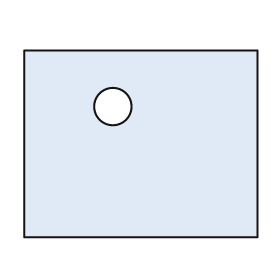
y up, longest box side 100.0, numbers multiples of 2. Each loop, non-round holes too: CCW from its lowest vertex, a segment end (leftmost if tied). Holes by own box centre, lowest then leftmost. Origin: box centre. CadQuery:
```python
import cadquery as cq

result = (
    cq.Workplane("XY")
    .moveTo(-50.0, -40.0)
    .lineTo(50.0, -40.0)
    .lineTo(50.0, 40.0)
    .lineTo(-50.0, 40.0)
    .close()
    .moveTo(-12.0, 16.0)
    .circle(8.0)
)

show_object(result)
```